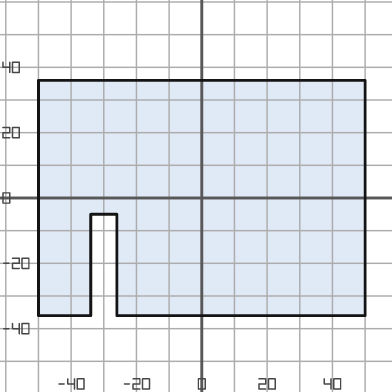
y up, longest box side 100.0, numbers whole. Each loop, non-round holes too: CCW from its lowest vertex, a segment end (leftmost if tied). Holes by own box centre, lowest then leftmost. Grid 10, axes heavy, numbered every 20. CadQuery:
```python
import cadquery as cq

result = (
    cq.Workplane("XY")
    .moveTo(-50.0, -36.0)
    .lineTo(-34.0, -36.0)
    .lineTo(-34.0, -5.0)
    .lineTo(-26.0, -5.0)
    .lineTo(-26.0, -36.0)
    .lineTo(50.0, -36.0)
    .lineTo(50.0, 36.0)
    .lineTo(-50.0, 36.0)
    .close()
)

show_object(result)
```